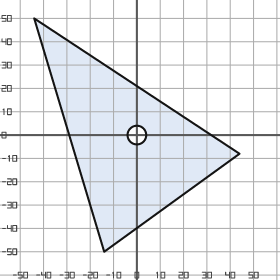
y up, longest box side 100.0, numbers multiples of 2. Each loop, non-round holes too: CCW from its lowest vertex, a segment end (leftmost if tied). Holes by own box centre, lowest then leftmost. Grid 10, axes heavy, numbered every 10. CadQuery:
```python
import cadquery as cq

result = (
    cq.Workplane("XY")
    .moveTo(-14.0, -50.0)
    .lineTo(44.0, -8.0)
    .lineTo(-44.0, 50.0)
    .close()
    .moveTo(0.0, 0.0)
    .circle(4.0)
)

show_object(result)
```